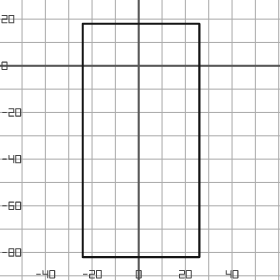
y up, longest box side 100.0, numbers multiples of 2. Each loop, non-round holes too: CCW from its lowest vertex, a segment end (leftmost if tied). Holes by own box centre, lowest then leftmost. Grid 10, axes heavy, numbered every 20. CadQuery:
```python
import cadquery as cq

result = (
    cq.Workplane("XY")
    .moveTo(-24.0, -82.0)
    .lineTo(26.0, -82.0)
    .lineTo(26.0, 18.0)
    .lineTo(-24.0, 18.0)
    .close()
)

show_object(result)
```